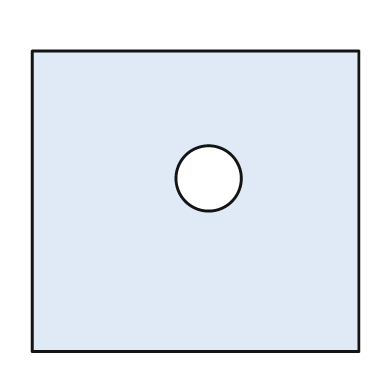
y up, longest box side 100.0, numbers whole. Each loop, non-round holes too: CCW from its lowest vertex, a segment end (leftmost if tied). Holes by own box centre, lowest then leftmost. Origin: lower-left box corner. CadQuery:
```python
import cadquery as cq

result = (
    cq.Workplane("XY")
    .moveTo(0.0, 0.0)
    .lineTo(100.0, 0.0)
    .lineTo(100.0, 92.0)
    .lineTo(0.0, 92.0)
    .close()
    .moveTo(54.0, 53.0)
    .circle(10.0)
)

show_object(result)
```